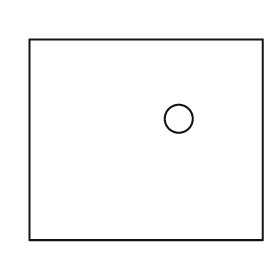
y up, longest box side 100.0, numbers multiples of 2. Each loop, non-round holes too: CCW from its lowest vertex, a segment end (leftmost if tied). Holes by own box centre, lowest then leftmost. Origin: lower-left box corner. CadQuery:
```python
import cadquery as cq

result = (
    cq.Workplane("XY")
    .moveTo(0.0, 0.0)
    .lineTo(100.0, 0.0)
    .lineTo(100.0, 86.0)
    .lineTo(0.0, 86.0)
    .close()
    .moveTo(64.0, 52.0)
    .circle(6.0)
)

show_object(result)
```